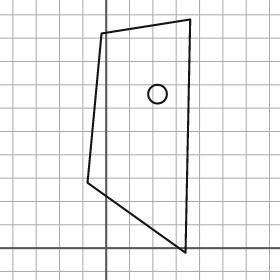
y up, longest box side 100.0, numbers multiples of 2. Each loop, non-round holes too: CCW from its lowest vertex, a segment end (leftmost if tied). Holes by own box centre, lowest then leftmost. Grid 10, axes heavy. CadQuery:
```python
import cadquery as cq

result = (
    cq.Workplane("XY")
    .moveTo(34.0, -2.0)
    .lineTo(36.0, 98.0)
    .lineTo(-2.0, 92.0)
    .lineTo(-8.0, 28.0)
    .close()
    .moveTo(22.0, 66.0)
    .circle(4.0)
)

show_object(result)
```